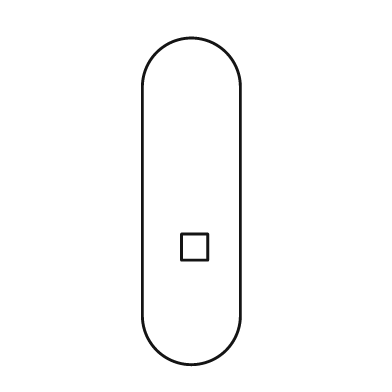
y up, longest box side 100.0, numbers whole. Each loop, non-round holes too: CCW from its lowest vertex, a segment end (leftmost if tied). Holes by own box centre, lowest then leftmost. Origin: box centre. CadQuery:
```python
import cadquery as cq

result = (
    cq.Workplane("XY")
    .moveTo(-15.0, -35.0)
    .threePointArc((0.0, -50.0), (15.0, -35.0))
    .lineTo(15.0, 35.0)
    .threePointArc((0.0, 50.0), (-15.0, 35.0))
    .close()
    .moveTo(-3.0, -18.0)
    .lineTo(5.0, -18.0)
    .lineTo(5.0, -10.0)
    .lineTo(-3.0, -10.0)
    .close()
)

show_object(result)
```